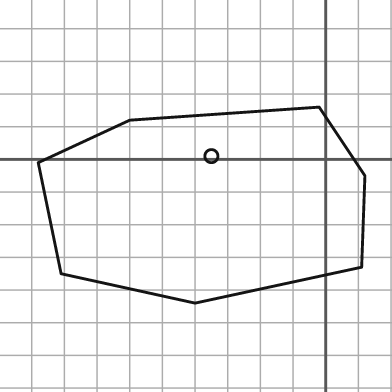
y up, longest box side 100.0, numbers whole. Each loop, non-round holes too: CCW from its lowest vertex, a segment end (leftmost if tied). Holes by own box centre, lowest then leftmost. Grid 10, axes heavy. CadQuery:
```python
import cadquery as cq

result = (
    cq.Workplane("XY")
    .moveTo(-40.0, -44.0)
    .lineTo(11.0, -33.0)
    .lineTo(12.0, -5.0)
    .lineTo(-2.0, 16.0)
    .lineTo(-60.0, 12.0)
    .lineTo(-88.0, -1.0)
    .lineTo(-81.0, -35.0)
    .close()
    .moveTo(-35.0, 1.0)
    .circle(2.0)
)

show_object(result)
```